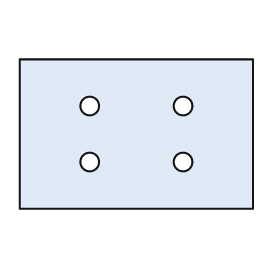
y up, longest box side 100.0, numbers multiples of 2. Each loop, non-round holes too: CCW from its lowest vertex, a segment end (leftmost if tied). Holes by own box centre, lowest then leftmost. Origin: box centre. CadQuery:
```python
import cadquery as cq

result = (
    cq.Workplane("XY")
    .moveTo(-50.0, -32.0)
    .lineTo(50.0, -32.0)
    .lineTo(50.0, 32.0)
    .lineTo(-50.0, 32.0)
    .close()
    .moveTo(-20.0, -12.0)
    .circle(4.0)
    .moveTo(20.0, -12.0)
    .circle(4.0)
    .moveTo(-20.0, 12.0)
    .circle(4.0)
    .moveTo(20.0, 12.0)
    .circle(4.0)
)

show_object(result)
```